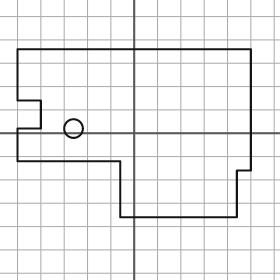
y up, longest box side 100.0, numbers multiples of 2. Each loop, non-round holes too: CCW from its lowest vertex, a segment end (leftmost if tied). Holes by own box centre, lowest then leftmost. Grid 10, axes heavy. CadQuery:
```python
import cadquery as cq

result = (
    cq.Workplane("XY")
    .moveTo(-6.0, -36.0)
    .lineTo(44.0, -36.0)
    .lineTo(44.0, -16.0)
    .lineTo(50.0, -16.0)
    .lineTo(50.0, 36.0)
    .lineTo(-50.0, 36.0)
    .lineTo(-50.0, 14.0)
    .lineTo(-40.0, 14.0)
    .lineTo(-40.0, 2.0)
    .lineTo(-50.0, 2.0)
    .lineTo(-50.0, -12.0)
    .lineTo(-6.0, -12.0)
    .close()
    .moveTo(-26.0, 2.0)
    .circle(4.0)
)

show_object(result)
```